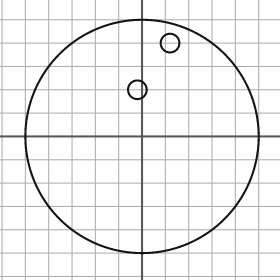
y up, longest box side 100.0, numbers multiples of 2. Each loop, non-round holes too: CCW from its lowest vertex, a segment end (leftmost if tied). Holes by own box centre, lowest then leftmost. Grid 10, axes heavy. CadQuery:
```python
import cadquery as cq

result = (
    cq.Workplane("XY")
    .moveTo(0.0, 0.0)
    .circle(50.0)
    .moveTo(-2.0, 20.0)
    .circle(4.0)
    .moveTo(12.0, 40.0)
    .circle(4.0)
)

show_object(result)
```